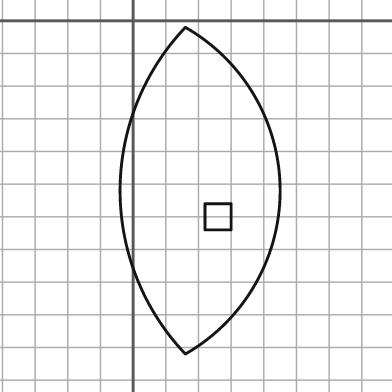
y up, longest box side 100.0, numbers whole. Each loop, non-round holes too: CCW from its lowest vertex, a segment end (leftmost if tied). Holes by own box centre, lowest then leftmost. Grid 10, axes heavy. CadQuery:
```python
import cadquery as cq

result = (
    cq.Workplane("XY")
    .moveTo(16.0, -102.0)
    .threePointArc((45.0, -52.0), (16.0, -2.0))
    .threePointArc((-4.0, -52.0), (16.0, -102.0))
    .close()
    .moveTo(22.0, -64.0)
    .lineTo(30.0, -64.0)
    .lineTo(30.0, -56.0)
    .lineTo(22.0, -56.0)
    .close()
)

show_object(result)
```